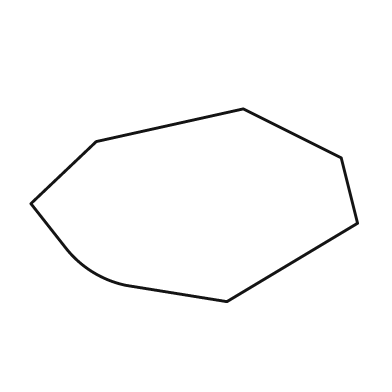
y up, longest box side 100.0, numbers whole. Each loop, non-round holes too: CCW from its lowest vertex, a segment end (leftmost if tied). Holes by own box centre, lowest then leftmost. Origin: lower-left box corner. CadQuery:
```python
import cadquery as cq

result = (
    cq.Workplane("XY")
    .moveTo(60.0, 0.0)
    .lineTo(100.0, 24.0)
    .lineTo(95.0, 44.0)
    .lineTo(65.0, 59.0)
    .lineTo(20.0, 49.0)
    .lineTo(0.0, 30.0)
    .lineTo(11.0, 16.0)
    .threePointArc((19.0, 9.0), (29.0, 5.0))
    .close()
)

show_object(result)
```